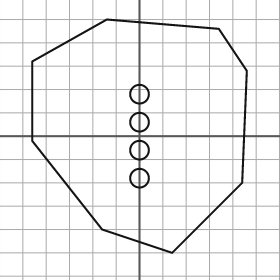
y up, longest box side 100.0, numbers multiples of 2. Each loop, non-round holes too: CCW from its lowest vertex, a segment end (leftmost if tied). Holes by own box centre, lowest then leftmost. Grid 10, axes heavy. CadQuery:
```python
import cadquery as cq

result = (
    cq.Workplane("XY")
    .moveTo(14.0, -50.0)
    .lineTo(44.0, -20.0)
    .lineTo(46.0, 28.0)
    .lineTo(34.0, 46.0)
    .lineTo(-14.0, 50.0)
    .lineTo(-46.0, 32.0)
    .lineTo(-46.0, -2.0)
    .lineTo(-16.0, -40.0)
    .close()
    .moveTo(0.0, -18.0)
    .circle(4.0)
    .moveTo(0.0, -6.0)
    .circle(4.0)
    .moveTo(0.0, 6.0)
    .circle(4.0)
    .moveTo(0.0, 18.0)
    .circle(4.0)
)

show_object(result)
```